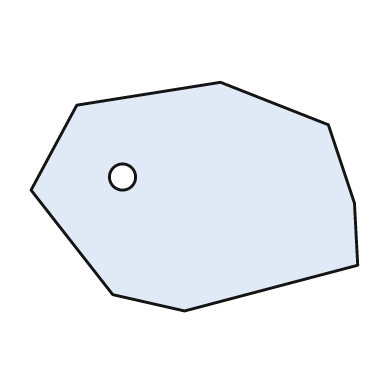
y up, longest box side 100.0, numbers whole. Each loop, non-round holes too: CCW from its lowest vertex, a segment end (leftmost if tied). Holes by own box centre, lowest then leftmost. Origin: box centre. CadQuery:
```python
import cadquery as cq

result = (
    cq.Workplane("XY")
    .moveTo(-3.0, -35.0)
    .lineTo(50.0, -21.0)
    .lineTo(49.0, -2.0)
    .lineTo(41.0, 22.0)
    .lineTo(8.0, 35.0)
    .lineTo(-36.0, 28.0)
    .lineTo(-50.0, 2.0)
    .lineTo(-25.0, -30.0)
    .close()
    .moveTo(-22.0, 6.0)
    .circle(4.0)
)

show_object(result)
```